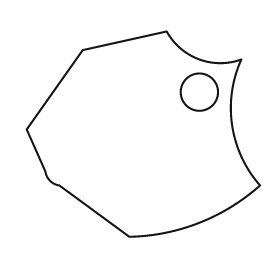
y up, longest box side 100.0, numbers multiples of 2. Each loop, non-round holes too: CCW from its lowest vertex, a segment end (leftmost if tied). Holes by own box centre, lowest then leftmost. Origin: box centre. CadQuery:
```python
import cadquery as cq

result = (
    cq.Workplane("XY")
    .moveTo(-6.0, -44.0)
    .threePointArc((24.0, -38.0), (50.0, -22.0))
    .threePointArc((38.0, 4.0), (42.0, 32.0))
    .threePointArc((24.0, 32.0), (10.0, 44.0))
    .lineTo(-26.0, 36.0)
    .lineTo(-50.0, 2.0)
    .lineTo(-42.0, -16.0)
    .threePointArc((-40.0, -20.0), (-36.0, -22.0))
    .close()
    .moveTo(24.0, 18.0)
    .circle(8.0)
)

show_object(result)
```